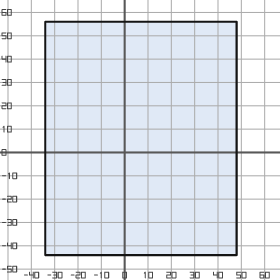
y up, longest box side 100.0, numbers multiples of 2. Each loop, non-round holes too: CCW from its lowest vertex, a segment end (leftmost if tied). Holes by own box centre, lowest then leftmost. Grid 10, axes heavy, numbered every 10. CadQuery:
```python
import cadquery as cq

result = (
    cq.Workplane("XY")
    .moveTo(-34.0, -44.0)
    .lineTo(48.0, -44.0)
    .lineTo(48.0, 56.0)
    .lineTo(-34.0, 56.0)
    .close()
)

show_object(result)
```